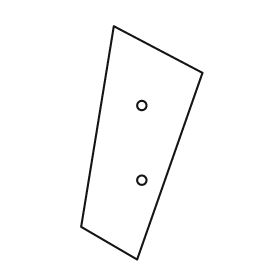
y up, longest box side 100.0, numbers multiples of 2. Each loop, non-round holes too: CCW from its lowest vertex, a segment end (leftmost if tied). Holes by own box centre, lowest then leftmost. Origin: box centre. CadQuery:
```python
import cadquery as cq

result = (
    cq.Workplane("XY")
    .moveTo(-2.0, -50.0)
    .lineTo(26.0, 30.0)
    .lineTo(-12.0, 50.0)
    .lineTo(-26.0, -36.0)
    .close()
    .moveTo(0.0, -16.0)
    .circle(2.0)
    .moveTo(0.0, 16.0)
    .circle(2.0)
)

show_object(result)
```